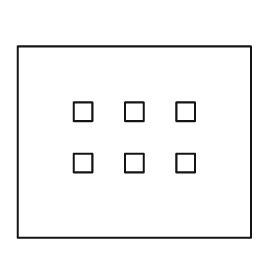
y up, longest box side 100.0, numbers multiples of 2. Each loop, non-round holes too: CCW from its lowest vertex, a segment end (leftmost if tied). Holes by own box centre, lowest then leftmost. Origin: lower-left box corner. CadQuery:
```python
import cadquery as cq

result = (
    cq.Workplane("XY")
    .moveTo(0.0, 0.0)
    .lineTo(100.0, 0.0)
    .lineTo(100.0, 82.0)
    .lineTo(0.0, 82.0)
    .close()
    .moveTo(24.0, 28.0)
    .lineTo(32.0, 28.0)
    .lineTo(32.0, 36.0)
    .lineTo(24.0, 36.0)
    .close()
    .moveTo(46.0, 28.0)
    .lineTo(54.0, 28.0)
    .lineTo(54.0, 36.0)
    .lineTo(46.0, 36.0)
    .close()
    .moveTo(68.0, 28.0)
    .lineTo(76.0, 28.0)
    .lineTo(76.0, 36.0)
    .lineTo(68.0, 36.0)
    .close()
    .moveTo(24.0, 50.0)
    .lineTo(32.0, 50.0)
    .lineTo(32.0, 58.0)
    .lineTo(24.0, 58.0)
    .close()
    .moveTo(46.0, 50.0)
    .lineTo(54.0, 50.0)
    .lineTo(54.0, 58.0)
    .lineTo(46.0, 58.0)
    .close()
    .moveTo(68.0, 50.0)
    .lineTo(76.0, 50.0)
    .lineTo(76.0, 58.0)
    .lineTo(68.0, 58.0)
    .close()
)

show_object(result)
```